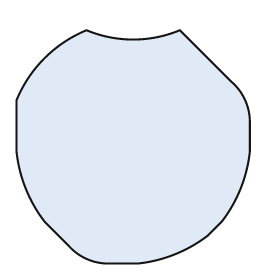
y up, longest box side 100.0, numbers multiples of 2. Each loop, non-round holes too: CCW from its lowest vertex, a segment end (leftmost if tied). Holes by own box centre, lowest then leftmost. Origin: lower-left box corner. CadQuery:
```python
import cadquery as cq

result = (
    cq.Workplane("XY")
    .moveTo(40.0, 0.0)
    .lineTo(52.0, 0.0)
    .threePointArc((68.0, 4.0), (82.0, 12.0))
    .lineTo(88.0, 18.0)
    .threePointArc((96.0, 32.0), (100.0, 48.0))
    .lineTo(100.0, 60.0)
    .threePointArc((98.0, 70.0), (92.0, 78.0))
    .lineTo(70.0, 100.0)
    .threePointArc((50.0, 96.0), (30.0, 100.0))
    .threePointArc((12.0, 88.0), (0.0, 70.0))
    .lineTo(0.0, 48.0)
    .threePointArc((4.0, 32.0), (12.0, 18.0))
    .lineTo(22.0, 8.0)
    .threePointArc((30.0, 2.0), (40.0, 0.0))
    .close()
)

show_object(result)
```